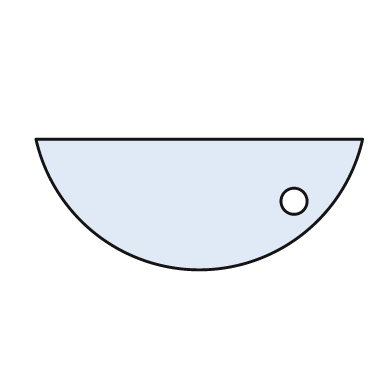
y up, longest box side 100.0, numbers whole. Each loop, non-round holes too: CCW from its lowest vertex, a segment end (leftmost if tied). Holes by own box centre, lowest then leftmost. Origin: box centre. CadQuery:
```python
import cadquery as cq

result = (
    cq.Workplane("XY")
    .moveTo(-50.0, 20.0)
    .threePointArc((0.0, -20.0), (50.0, 20.0))
    .close()
    .moveTo(29.0, 1.0)
    .circle(4.0)
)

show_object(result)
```